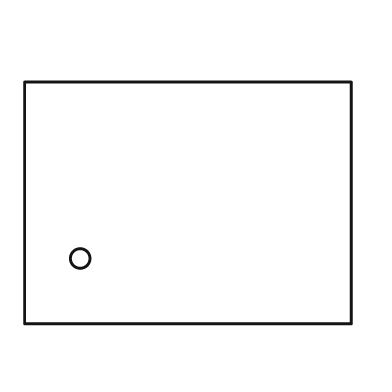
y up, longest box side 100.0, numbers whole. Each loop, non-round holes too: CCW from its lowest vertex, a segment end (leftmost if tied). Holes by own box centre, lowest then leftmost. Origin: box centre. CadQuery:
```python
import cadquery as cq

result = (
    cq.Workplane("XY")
    .moveTo(-50.0, -37.0)
    .lineTo(50.0, -37.0)
    .lineTo(50.0, 37.0)
    .lineTo(-50.0, 37.0)
    .close()
    .moveTo(-33.0, -17.0)
    .circle(3.0)
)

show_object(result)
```